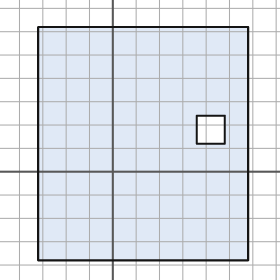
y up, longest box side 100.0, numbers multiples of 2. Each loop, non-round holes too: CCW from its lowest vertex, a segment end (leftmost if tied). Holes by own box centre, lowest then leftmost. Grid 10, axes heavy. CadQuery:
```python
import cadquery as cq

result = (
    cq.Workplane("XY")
    .moveTo(-32.0, -38.0)
    .lineTo(58.0, -38.0)
    .lineTo(58.0, 62.0)
    .lineTo(-32.0, 62.0)
    .close()
    .moveTo(36.0, 12.0)
    .lineTo(48.0, 12.0)
    .lineTo(48.0, 24.0)
    .lineTo(36.0, 24.0)
    .close()
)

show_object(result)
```